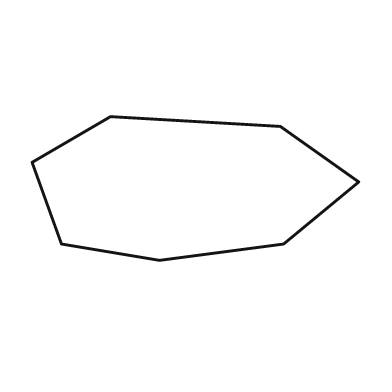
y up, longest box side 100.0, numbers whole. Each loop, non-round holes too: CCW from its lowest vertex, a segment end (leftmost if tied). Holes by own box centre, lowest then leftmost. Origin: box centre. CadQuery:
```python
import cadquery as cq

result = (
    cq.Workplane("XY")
    .moveTo(-11.0, -22.0)
    .lineTo(27.0, -17.0)
    .lineTo(50.0, 2.0)
    .lineTo(26.0, 19.0)
    .lineTo(-26.0, 22.0)
    .lineTo(-50.0, 8.0)
    .lineTo(-41.0, -17.0)
    .close()
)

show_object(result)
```